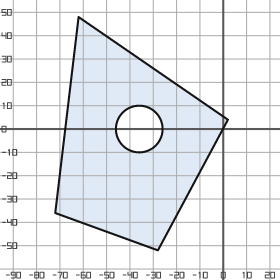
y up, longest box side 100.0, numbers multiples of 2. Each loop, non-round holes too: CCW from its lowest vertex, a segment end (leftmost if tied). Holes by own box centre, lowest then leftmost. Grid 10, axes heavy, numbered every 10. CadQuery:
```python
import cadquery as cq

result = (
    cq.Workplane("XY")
    .moveTo(-28.0, -52.0)
    .lineTo(2.0, 4.0)
    .lineTo(-62.0, 48.0)
    .lineTo(-72.0, -36.0)
    .close()
    .moveTo(-36.0, 0.0)
    .circle(10.0)
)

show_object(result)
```